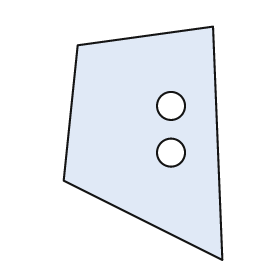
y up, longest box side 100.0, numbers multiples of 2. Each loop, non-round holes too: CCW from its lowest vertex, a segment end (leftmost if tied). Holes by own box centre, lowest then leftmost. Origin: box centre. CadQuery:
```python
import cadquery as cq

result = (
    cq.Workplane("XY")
    .moveTo(34.0, -50.0)
    .lineTo(30.0, 50.0)
    .lineTo(-28.0, 42.0)
    .lineTo(-34.0, -16.0)
    .close()
    .moveTo(12.0, -4.0)
    .circle(6.0)
    .moveTo(12.0, 16.0)
    .circle(6.0)
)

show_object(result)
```